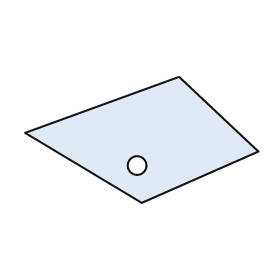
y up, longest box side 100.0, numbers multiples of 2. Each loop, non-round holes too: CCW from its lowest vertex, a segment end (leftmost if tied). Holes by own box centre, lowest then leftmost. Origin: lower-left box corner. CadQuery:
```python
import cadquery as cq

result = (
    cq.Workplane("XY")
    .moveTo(50.0, 0.0)
    .lineTo(100.0, 22.0)
    .lineTo(66.0, 54.0)
    .lineTo(0.0, 30.0)
    .close()
    .moveTo(48.0, 16.0)
    .circle(4.0)
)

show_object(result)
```